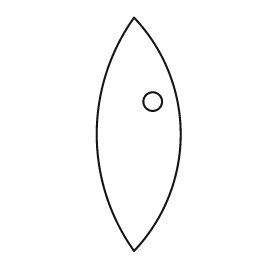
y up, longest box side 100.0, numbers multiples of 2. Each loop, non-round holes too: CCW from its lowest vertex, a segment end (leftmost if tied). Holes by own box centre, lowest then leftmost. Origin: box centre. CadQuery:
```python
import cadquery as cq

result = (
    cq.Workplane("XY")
    .moveTo(-2.0, -50.0)
    .threePointArc((18.0, 0.0), (-2.0, 50.0))
    .threePointArc((-18.0, 0.0), (-2.0, -50.0))
    .close()
    .moveTo(6.0, 14.0)
    .circle(4.0)
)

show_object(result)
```